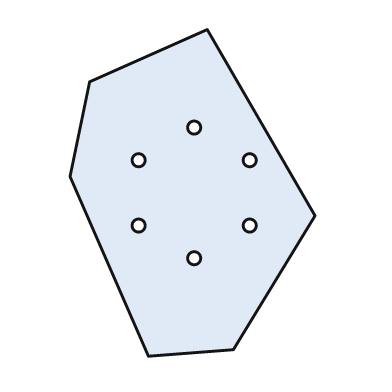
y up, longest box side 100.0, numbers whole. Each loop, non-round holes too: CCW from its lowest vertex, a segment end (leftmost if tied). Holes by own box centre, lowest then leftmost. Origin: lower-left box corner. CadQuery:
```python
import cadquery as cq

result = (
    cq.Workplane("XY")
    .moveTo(24.0, 0.0)
    .lineTo(50.0, 2.0)
    .lineTo(75.0, 43.0)
    .lineTo(42.0, 100.0)
    .lineTo(6.0, 84.0)
    .lineTo(0.0, 55.0)
    .close()
    .moveTo(38.0, 30.0)
    .circle(2.0)
    .moveTo(21.0, 40.0)
    .circle(2.0)
    .moveTo(55.0, 40.0)
    .circle(2.0)
    .moveTo(21.0, 60.0)
    .circle(2.0)
    .moveTo(55.0, 60.0)
    .circle(2.0)
    .moveTo(38.0, 70.0)
    .circle(2.0)
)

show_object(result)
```